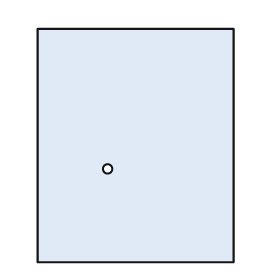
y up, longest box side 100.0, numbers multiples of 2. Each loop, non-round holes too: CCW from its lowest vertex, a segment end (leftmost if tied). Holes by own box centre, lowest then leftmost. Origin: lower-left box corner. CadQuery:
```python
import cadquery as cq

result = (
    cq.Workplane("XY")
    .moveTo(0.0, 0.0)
    .lineTo(84.0, 0.0)
    .lineTo(84.0, 100.0)
    .lineTo(0.0, 100.0)
    .close()
    .moveTo(30.0, 40.0)
    .circle(2.0)
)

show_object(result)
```